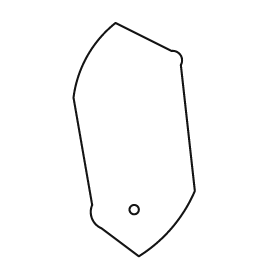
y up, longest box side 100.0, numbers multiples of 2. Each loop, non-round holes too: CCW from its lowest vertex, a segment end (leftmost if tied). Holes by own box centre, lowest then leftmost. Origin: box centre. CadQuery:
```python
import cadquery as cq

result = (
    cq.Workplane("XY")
    .moveTo(2.0, -50.0)
    .threePointArc((16.0, -38.0), (26.0, -22.0))
    .lineTo(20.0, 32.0)
    .threePointArc((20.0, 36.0), (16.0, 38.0))
    .lineTo(-8.0, 50.0)
    .threePointArc((-20.0, 36.0), (-26.0, 18.0))
    .lineTo(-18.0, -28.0)
    .threePointArc((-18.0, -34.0), (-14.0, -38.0))
    .close()
    .moveTo(0.0, -30.0)
    .circle(2.0)
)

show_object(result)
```